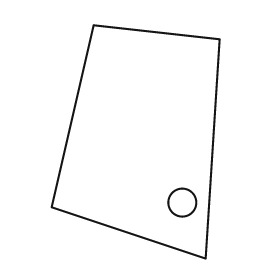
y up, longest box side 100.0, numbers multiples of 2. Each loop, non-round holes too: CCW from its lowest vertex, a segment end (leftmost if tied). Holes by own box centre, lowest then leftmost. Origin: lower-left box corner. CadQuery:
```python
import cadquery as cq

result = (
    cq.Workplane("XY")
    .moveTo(66.0, 0.0)
    .lineTo(72.0, 94.0)
    .lineTo(18.0, 100.0)
    .lineTo(0.0, 22.0)
    .close()
    .moveTo(56.0, 24.0)
    .circle(6.0)
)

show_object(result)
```